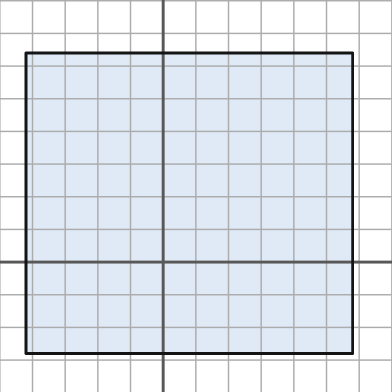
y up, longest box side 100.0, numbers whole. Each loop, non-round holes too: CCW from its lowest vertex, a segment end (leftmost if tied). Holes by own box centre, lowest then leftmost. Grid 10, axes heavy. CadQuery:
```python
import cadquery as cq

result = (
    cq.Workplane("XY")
    .moveTo(-42.0, -28.0)
    .lineTo(58.0, -28.0)
    .lineTo(58.0, 64.0)
    .lineTo(-42.0, 64.0)
    .close()
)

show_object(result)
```